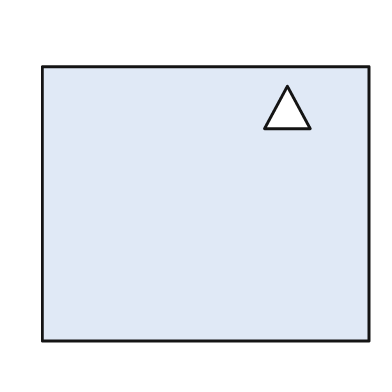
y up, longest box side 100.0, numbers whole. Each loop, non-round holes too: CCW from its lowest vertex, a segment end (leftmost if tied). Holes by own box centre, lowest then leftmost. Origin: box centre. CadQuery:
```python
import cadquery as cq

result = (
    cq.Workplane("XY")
    .moveTo(-50.0, -42.0)
    .lineTo(50.0, -42.0)
    .lineTo(50.0, 42.0)
    .lineTo(-50.0, 42.0)
    .close()
    .moveTo(18.0, 23.0)
    .lineTo(32.0, 23.0)
    .lineTo(25.0, 36.0)
    .close()
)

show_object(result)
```